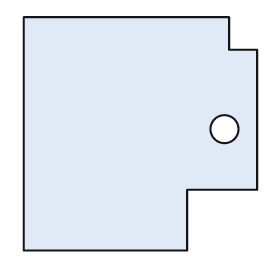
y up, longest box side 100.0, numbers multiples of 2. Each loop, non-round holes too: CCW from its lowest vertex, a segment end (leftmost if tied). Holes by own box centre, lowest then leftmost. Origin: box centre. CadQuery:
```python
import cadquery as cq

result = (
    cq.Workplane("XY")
    .moveTo(-50.0, -50.0)
    .lineTo(20.0, -50.0)
    .lineTo(20.0, -24.0)
    .lineTo(50.0, -24.0)
    .lineTo(50.0, 36.0)
    .lineTo(38.0, 36.0)
    .lineTo(38.0, 50.0)
    .lineTo(-50.0, 50.0)
    .close()
    .moveTo(36.0, 2.0)
    .circle(6.0)
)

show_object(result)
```